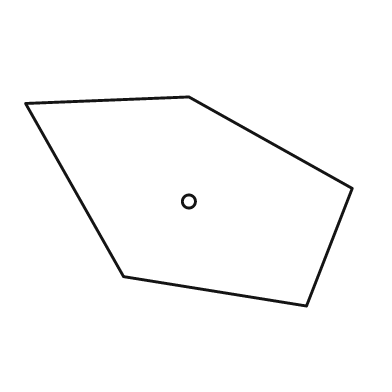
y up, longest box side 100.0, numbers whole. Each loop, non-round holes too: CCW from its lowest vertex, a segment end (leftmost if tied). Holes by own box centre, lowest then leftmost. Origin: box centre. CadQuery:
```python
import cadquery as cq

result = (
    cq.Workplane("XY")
    .moveTo(36.0, -32.0)
    .lineTo(50.0, 4.0)
    .lineTo(0.0, 32.0)
    .lineTo(-50.0, 30.0)
    .lineTo(-20.0, -23.0)
    .close()
    .moveTo(0.0, 0.0)
    .circle(2.0)
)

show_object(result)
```